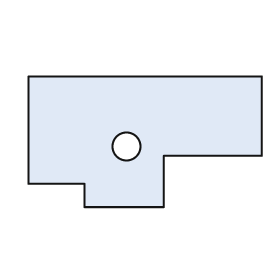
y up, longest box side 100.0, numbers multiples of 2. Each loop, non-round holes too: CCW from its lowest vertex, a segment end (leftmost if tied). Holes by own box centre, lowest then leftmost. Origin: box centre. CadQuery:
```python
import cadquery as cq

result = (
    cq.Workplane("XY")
    .moveTo(-26.0, -28.0)
    .lineTo(8.0, -28.0)
    .lineTo(8.0, -6.0)
    .lineTo(50.0, -6.0)
    .lineTo(50.0, 28.0)
    .lineTo(-50.0, 28.0)
    .lineTo(-50.0, -18.0)
    .lineTo(-26.0, -18.0)
    .close()
    .moveTo(-8.0, -2.0)
    .circle(6.0)
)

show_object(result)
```